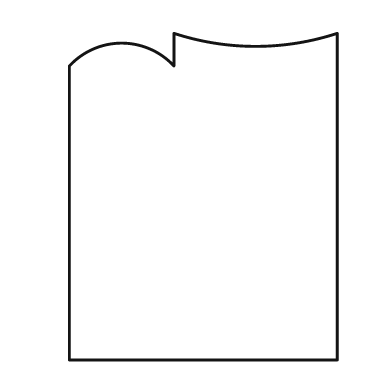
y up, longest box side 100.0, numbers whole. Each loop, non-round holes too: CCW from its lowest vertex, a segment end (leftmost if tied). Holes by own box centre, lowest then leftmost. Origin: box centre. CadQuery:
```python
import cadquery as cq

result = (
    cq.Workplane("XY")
    .moveTo(-41.0, -50.0)
    .lineTo(41.0, -50.0)
    .lineTo(41.0, 50.0)
    .threePointArc((16.0, 46.0), (-9.0, 50.0))
    .lineTo(-9.0, 40.0)
    .threePointArc((-25.0, 47.0), (-41.0, 40.0))
    .close()
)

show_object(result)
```